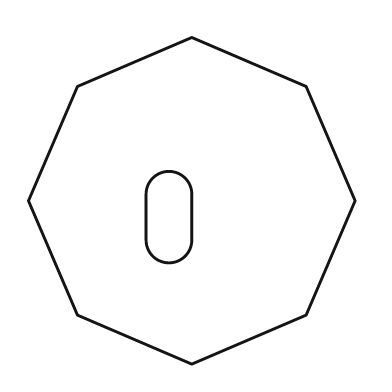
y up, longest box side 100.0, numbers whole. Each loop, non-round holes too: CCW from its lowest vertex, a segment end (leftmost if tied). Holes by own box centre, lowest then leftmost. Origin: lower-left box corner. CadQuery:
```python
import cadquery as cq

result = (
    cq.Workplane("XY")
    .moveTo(50.0, 0.0)
    .lineTo(85.0, 15.0)
    .lineTo(100.0, 50.0)
    .lineTo(85.0, 85.0)
    .lineTo(50.0, 100.0)
    .lineTo(15.0, 85.0)
    .lineTo(0.0, 50.0)
    .lineTo(15.0, 15.0)
    .close()
    .moveTo(36.0, 38.0)
    .threePointArc((43.0, 31.0), (50.0, 38.0))
    .lineTo(50.0, 52.0)
    .threePointArc((43.0, 59.0), (36.0, 52.0))
    .close()
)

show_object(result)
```